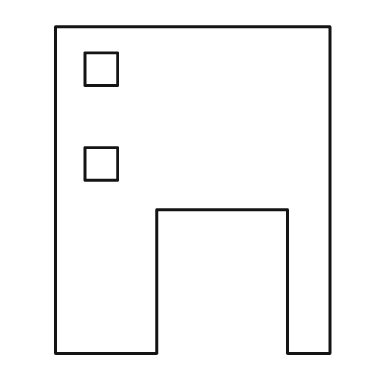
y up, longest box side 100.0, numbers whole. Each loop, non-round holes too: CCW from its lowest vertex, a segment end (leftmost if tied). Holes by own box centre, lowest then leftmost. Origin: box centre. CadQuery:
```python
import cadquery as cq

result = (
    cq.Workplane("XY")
    .moveTo(-42.0, -50.0)
    .lineTo(-11.0, -50.0)
    .lineTo(-11.0, -6.0)
    .lineTo(29.0, -6.0)
    .lineTo(29.0, -50.0)
    .lineTo(42.0, -50.0)
    .lineTo(42.0, 50.0)
    .lineTo(-42.0, 50.0)
    .close()
    .moveTo(-33.0, 3.0)
    .lineTo(-23.0, 3.0)
    .lineTo(-23.0, 13.0)
    .lineTo(-33.0, 13.0)
    .close()
    .moveTo(-33.0, 32.0)
    .lineTo(-23.0, 32.0)
    .lineTo(-23.0, 42.0)
    .lineTo(-33.0, 42.0)
    .close()
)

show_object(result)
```